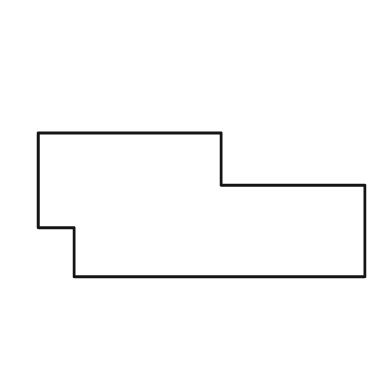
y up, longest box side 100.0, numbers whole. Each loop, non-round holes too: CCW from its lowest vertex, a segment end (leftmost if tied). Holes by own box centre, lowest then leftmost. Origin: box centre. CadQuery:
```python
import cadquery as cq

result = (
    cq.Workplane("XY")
    .moveTo(-39.0, -22.0)
    .lineTo(50.0, -22.0)
    .lineTo(50.0, 6.0)
    .lineTo(6.0, 6.0)
    .lineTo(6.0, 22.0)
    .lineTo(-50.0, 22.0)
    .lineTo(-50.0, -7.0)
    .lineTo(-39.0, -7.0)
    .close()
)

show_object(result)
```